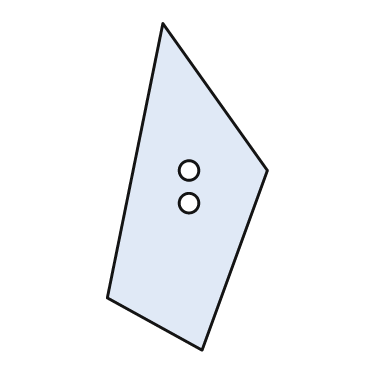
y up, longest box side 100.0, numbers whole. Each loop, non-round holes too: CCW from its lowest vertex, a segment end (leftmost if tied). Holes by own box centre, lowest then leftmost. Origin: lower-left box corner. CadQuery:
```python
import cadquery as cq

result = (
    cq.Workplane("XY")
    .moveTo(29.0, 0.0)
    .lineTo(49.0, 55.0)
    .lineTo(17.0, 100.0)
    .lineTo(0.0, 16.0)
    .close()
    .moveTo(25.0, 45.0)
    .circle(3.0)
    .moveTo(25.0, 55.0)
    .circle(3.0)
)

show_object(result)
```